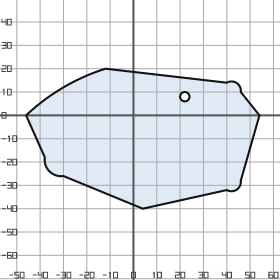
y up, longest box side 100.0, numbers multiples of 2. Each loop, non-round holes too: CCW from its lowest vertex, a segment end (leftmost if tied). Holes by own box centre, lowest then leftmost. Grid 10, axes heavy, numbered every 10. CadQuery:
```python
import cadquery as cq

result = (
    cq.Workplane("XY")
    .moveTo(4.0, -40.0)
    .lineTo(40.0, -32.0)
    .threePointArc((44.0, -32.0), (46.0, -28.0))
    .lineTo(54.0, 0.0)
    .lineTo(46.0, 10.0)
    .threePointArc((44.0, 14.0), (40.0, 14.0))
    .lineTo(-12.0, 20.0)
    .threePointArc((-30.0, 12.0), (-46.0, 0.0))
    .lineTo(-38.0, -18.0)
    .threePointArc((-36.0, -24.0), (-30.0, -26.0))
    .close()
    .moveTo(22.0, 8.0)
    .circle(2.0)
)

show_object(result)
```